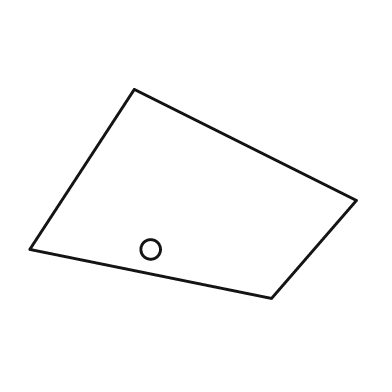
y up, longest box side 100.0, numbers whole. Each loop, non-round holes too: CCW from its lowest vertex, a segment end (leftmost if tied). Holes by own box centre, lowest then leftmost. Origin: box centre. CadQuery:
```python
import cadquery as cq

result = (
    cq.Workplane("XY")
    .moveTo(24.0, -32.0)
    .lineTo(50.0, -2.0)
    .lineTo(-18.0, 32.0)
    .lineTo(-50.0, -17.0)
    .close()
    .moveTo(-13.0, -17.0)
    .circle(3.0)
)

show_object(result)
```